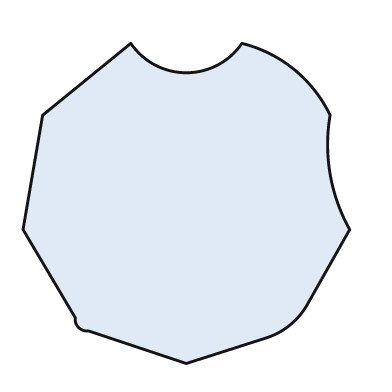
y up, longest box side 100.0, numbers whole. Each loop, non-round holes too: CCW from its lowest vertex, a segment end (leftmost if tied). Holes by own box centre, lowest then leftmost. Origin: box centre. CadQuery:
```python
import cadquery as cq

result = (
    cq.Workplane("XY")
    .moveTo(0.0, -49.0)
    .lineTo(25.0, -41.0)
    .threePointArc((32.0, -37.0), (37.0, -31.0))
    .lineTo(50.0, -8.0)
    .threePointArc((44.0, 9.0), (44.0, 27.0))
    .threePointArc((33.0, 41.0), (17.0, 49.0))
    .threePointArc((0.0, 40.0), (-17.0, 49.0))
    .lineTo(-44.0, 27.0)
    .lineTo(-50.0, -8.0)
    .lineTo(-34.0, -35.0)
    .threePointArc((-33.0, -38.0), (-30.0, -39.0))
    .close()
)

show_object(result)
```